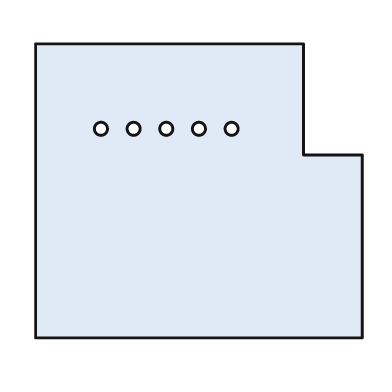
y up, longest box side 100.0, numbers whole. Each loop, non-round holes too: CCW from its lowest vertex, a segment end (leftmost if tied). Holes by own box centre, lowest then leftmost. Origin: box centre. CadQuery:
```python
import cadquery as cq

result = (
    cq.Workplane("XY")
    .moveTo(-50.0, -45.0)
    .lineTo(50.0, -45.0)
    .lineTo(50.0, 11.0)
    .lineTo(32.0, 11.0)
    .lineTo(32.0, 45.0)
    .lineTo(-50.0, 45.0)
    .close()
    .moveTo(-30.0, 19.0)
    .circle(2.0)
    .moveTo(-20.0, 19.0)
    .circle(2.0)
    .moveTo(-10.0, 19.0)
    .circle(2.0)
    .moveTo(0.0, 19.0)
    .circle(2.0)
    .moveTo(10.0, 19.0)
    .circle(2.0)
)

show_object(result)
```